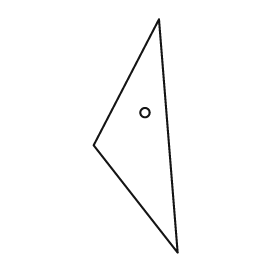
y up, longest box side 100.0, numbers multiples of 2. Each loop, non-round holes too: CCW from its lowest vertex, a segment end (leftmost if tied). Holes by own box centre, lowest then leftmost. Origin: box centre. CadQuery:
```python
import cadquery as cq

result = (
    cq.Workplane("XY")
    .moveTo(18.0, -50.0)
    .lineTo(10.0, 50.0)
    .lineTo(-18.0, -4.0)
    .close()
    .moveTo(4.0, 10.0)
    .circle(2.0)
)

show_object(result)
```